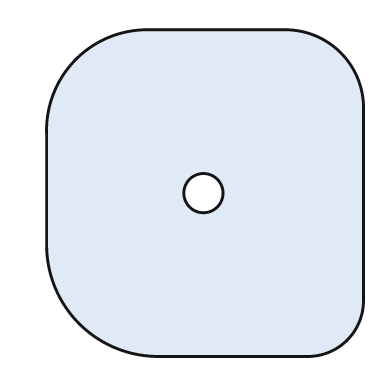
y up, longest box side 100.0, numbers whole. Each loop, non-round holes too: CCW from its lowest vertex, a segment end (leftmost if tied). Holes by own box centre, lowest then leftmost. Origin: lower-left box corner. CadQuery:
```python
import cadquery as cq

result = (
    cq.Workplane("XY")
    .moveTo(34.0, 0.0)
    .lineTo(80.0, 0.0)
    .threePointArc((92.0, 5.0), (97.0, 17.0))
    .lineTo(97.0, 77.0)
    .threePointArc((90.0, 93.0), (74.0, 100.0))
    .lineTo(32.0, 100.0)
    .threePointArc((9.0, 91.0), (0.0, 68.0))
    .lineTo(0.0, 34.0)
    .threePointArc((10.0, 10.0), (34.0, 0.0))
    .close()
    .moveTo(48.0, 50.0)
    .circle(6.0)
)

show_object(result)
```